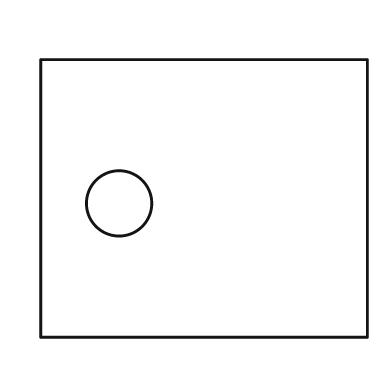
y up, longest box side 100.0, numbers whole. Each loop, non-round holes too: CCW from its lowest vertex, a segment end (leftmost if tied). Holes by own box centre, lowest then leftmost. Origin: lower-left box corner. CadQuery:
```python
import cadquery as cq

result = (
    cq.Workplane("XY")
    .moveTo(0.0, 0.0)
    .lineTo(100.0, 0.0)
    .lineTo(100.0, 85.0)
    .lineTo(0.0, 85.0)
    .close()
    .moveTo(24.0, 41.0)
    .circle(10.0)
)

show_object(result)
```